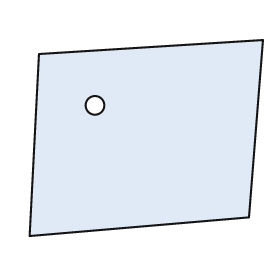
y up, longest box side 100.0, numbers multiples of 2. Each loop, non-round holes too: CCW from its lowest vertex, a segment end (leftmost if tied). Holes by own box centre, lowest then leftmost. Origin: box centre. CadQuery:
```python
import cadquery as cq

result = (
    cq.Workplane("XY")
    .moveTo(-50.0, -42.0)
    .lineTo(44.0, -34.0)
    .lineTo(50.0, 42.0)
    .lineTo(-46.0, 36.0)
    .close()
    .moveTo(-22.0, 14.0)
    .circle(4.0)
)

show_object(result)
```